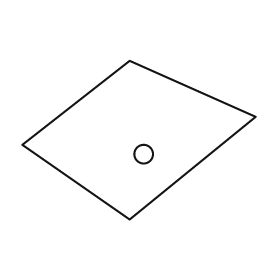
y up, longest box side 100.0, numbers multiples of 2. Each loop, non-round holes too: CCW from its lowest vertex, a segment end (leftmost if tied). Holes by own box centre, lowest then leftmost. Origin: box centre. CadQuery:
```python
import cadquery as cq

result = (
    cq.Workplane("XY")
    .moveTo(-4.0, -34.0)
    .lineTo(50.0, 10.0)
    .lineTo(-4.0, 34.0)
    .lineTo(-50.0, -2.0)
    .close()
    .moveTo(2.0, -6.0)
    .circle(4.0)
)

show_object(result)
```